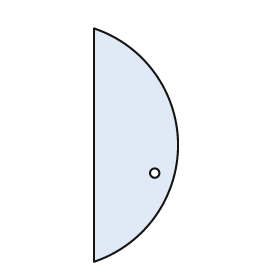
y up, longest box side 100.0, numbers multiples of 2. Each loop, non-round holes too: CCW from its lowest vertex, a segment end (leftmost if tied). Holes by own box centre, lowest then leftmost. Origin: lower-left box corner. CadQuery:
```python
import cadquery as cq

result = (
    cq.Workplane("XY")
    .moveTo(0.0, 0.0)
    .threePointArc((36.0, 50.0), (0.0, 100.0))
    .close()
    .moveTo(26.0, 38.0)
    .circle(2.0)
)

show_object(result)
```